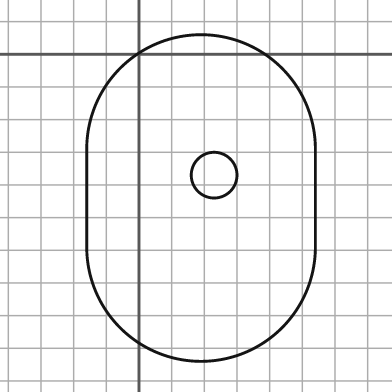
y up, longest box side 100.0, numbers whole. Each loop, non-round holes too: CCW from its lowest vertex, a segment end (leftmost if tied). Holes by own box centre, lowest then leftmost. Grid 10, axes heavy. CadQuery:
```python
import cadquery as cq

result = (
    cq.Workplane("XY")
    .moveTo(-16.0, -59.0)
    .threePointArc((19.0, -94.0), (54.0, -59.0))
    .lineTo(54.0, -29.0)
    .threePointArc((19.0, 6.0), (-16.0, -29.0))
    .close()
    .moveTo(23.0, -37.0)
    .circle(7.0)
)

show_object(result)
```